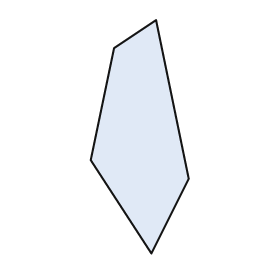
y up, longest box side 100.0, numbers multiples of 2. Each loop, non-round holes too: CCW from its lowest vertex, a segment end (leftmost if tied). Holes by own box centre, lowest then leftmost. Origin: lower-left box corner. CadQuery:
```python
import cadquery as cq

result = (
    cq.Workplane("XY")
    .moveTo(26.0, 0.0)
    .lineTo(42.0, 32.0)
    .lineTo(28.0, 100.0)
    .lineTo(10.0, 88.0)
    .lineTo(0.0, 40.0)
    .close()
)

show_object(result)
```